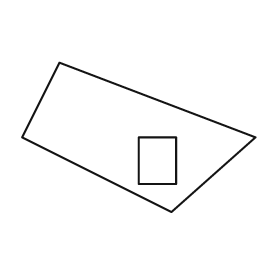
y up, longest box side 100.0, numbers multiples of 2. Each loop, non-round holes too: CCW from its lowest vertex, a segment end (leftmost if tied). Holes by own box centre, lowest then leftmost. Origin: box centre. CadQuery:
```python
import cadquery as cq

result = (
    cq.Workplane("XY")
    .moveTo(14.0, -32.0)
    .lineTo(50.0, 0.0)
    .lineTo(-34.0, 32.0)
    .lineTo(-50.0, 0.0)
    .close()
    .moveTo(0.0, -20.0)
    .lineTo(16.0, -20.0)
    .lineTo(16.0, 0.0)
    .lineTo(0.0, 0.0)
    .close()
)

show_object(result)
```